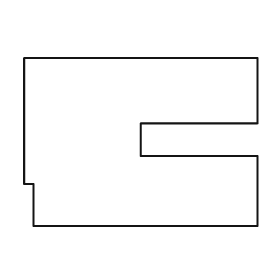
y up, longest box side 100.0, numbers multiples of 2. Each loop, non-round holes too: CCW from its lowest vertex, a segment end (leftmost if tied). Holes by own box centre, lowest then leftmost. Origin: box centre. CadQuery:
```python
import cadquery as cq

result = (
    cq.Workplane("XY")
    .moveTo(-46.0, -36.0)
    .lineTo(50.0, -36.0)
    .lineTo(50.0, -6.0)
    .lineTo(0.0, -6.0)
    .lineTo(0.0, 8.0)
    .lineTo(50.0, 8.0)
    .lineTo(50.0, 36.0)
    .lineTo(-50.0, 36.0)
    .lineTo(-50.0, -18.0)
    .lineTo(-46.0, -18.0)
    .close()
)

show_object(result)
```